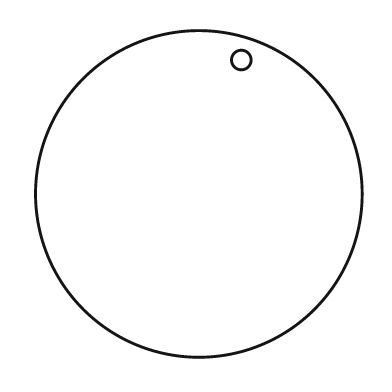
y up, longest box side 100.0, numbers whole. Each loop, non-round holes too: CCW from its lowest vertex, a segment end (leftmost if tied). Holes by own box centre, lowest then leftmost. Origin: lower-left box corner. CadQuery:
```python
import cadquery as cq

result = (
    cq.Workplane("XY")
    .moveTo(50.0, 50.0)
    .circle(50.0)
    .moveTo(63.0, 91.0)
    .circle(3.0)
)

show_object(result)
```